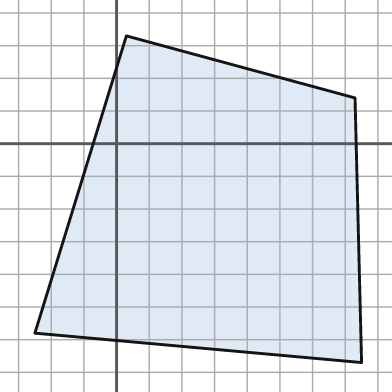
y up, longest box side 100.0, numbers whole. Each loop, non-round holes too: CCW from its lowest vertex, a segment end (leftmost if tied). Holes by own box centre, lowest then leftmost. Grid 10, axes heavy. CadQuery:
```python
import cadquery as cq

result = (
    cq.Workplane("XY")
    .moveTo(75.0, -67.0)
    .lineTo(73.0, 14.0)
    .lineTo(3.0, 33.0)
    .lineTo(-25.0, -58.0)
    .close()
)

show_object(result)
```